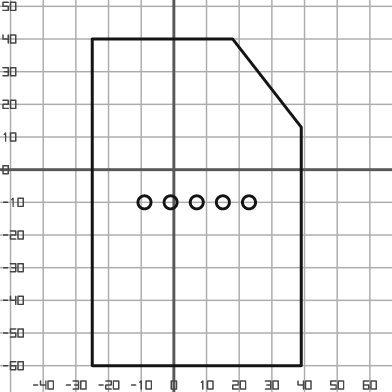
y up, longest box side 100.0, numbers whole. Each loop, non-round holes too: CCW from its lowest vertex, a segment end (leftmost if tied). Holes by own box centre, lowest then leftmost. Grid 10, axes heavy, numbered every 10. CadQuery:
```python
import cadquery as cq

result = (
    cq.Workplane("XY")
    .moveTo(-25.0, -60.0)
    .lineTo(39.0, -60.0)
    .lineTo(39.0, 13.0)
    .lineTo(18.0, 40.0)
    .lineTo(-25.0, 40.0)
    .close()
    .moveTo(-9.0, -10.0)
    .circle(2.0)
    .moveTo(-1.0, -10.0)
    .circle(2.0)
    .moveTo(7.0, -10.0)
    .circle(2.0)
    .moveTo(15.0, -10.0)
    .circle(2.0)
    .moveTo(23.0, -10.0)
    .circle(2.0)
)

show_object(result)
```